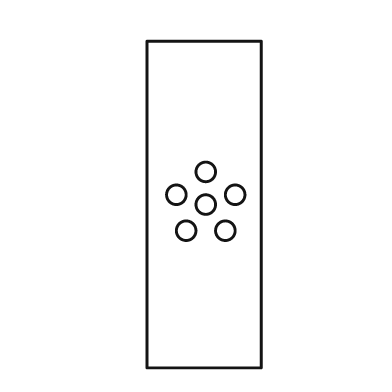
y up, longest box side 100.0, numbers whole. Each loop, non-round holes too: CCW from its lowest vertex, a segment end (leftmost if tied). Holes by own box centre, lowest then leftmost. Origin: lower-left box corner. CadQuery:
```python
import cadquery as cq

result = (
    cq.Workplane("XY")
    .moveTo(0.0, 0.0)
    .lineTo(35.0, 0.0)
    .lineTo(35.0, 100.0)
    .lineTo(0.0, 100.0)
    .close()
    .moveTo(12.0, 42.0)
    .circle(3.0)
    .moveTo(24.0, 42.0)
    .circle(3.0)
    .moveTo(18.0, 50.0)
    .circle(3.0)
    .moveTo(9.0, 53.0)
    .circle(3.0)
    .moveTo(27.0, 53.0)
    .circle(3.0)
    .moveTo(18.0, 60.0)
    .circle(3.0)
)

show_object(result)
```